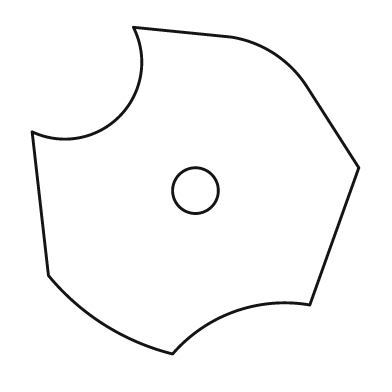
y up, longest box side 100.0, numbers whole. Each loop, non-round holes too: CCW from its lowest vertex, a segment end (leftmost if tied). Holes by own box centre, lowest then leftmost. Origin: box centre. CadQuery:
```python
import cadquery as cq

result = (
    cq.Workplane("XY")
    .moveTo(-7.0, -50.0)
    .threePointArc((12.0, -37.0), (35.0, -35.0))
    .lineTo(50.0, 7.0)
    .lineTo(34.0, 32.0)
    .threePointArc((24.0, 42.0), (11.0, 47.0))
    .lineTo(-19.0, 50.0)
    .threePointArc((-23.0, 23.0), (-50.0, 18.0))
    .lineTo(-45.0, -26.0)
    .threePointArc((-28.0, -41.0), (-7.0, -50.0))
    .close()
    .moveTo(0.0, 0.0)
    .circle(7.0)
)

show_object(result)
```